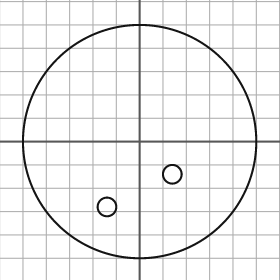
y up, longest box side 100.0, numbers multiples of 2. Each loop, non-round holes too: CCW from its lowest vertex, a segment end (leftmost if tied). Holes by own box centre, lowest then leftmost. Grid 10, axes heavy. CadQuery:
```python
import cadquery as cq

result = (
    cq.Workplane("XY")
    .moveTo(0.0, 0.0)
    .circle(50.0)
    .moveTo(-14.0, -28.0)
    .circle(4.0)
    .moveTo(14.0, -14.0)
    .circle(4.0)
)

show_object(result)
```